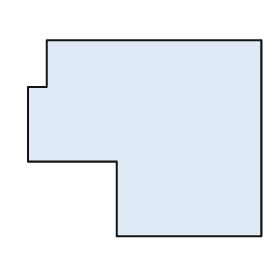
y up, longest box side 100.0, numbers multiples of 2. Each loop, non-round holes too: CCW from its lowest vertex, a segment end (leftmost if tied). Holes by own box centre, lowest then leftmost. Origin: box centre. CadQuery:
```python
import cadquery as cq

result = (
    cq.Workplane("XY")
    .moveTo(-12.0, -42.0)
    .lineTo(50.0, -42.0)
    .lineTo(50.0, 42.0)
    .lineTo(-42.0, 42.0)
    .lineTo(-42.0, 22.0)
    .lineTo(-50.0, 22.0)
    .lineTo(-50.0, -10.0)
    .lineTo(-12.0, -10.0)
    .close()
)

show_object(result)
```